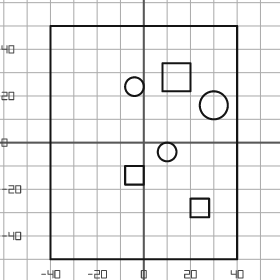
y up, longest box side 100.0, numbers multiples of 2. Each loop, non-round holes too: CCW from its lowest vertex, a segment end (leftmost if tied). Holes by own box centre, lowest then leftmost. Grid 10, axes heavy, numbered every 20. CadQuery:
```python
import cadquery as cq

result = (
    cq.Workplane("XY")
    .moveTo(-40.0, -50.0)
    .lineTo(40.0, -50.0)
    .lineTo(40.0, 50.0)
    .lineTo(-40.0, 50.0)
    .close()
    .moveTo(20.0, -32.0)
    .lineTo(28.0, -32.0)
    .lineTo(28.0, -24.0)
    .lineTo(20.0, -24.0)
    .close()
    .moveTo(-8.0, -18.0)
    .lineTo(0.0, -18.0)
    .lineTo(0.0, -10.0)
    .lineTo(-8.0, -10.0)
    .close()
    .moveTo(10.0, -4.0)
    .circle(4.0)
    .moveTo(30.0, 16.0)
    .circle(6.0)
    .moveTo(-4.0, 24.0)
    .circle(4.0)
    .moveTo(8.0, 22.0)
    .lineTo(20.0, 22.0)
    .lineTo(20.0, 34.0)
    .lineTo(8.0, 34.0)
    .close()
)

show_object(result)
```